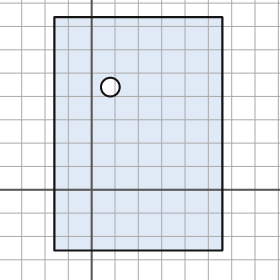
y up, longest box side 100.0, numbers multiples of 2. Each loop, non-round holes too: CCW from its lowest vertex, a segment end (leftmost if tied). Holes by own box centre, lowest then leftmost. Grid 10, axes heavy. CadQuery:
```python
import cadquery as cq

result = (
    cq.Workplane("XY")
    .moveTo(-16.0, -26.0)
    .lineTo(56.0, -26.0)
    .lineTo(56.0, 74.0)
    .lineTo(-16.0, 74.0)
    .close()
    .moveTo(8.0, 44.0)
    .circle(4.0)
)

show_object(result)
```